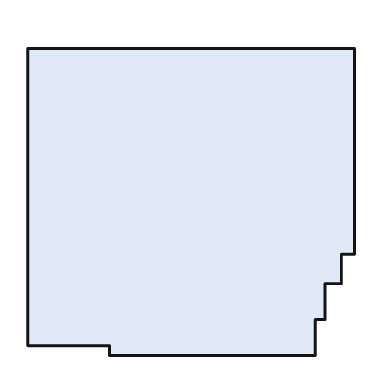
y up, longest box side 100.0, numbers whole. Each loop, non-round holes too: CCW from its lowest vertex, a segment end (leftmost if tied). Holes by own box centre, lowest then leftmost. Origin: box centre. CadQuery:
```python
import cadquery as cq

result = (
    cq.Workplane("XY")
    .moveTo(-25.0, -47.0)
    .lineTo(38.0, -47.0)
    .lineTo(38.0, -36.0)
    .lineTo(41.0, -36.0)
    .lineTo(41.0, -25.0)
    .lineTo(46.0, -25.0)
    .lineTo(46.0, -16.0)
    .lineTo(50.0, -16.0)
    .lineTo(50.0, 47.0)
    .lineTo(-50.0, 47.0)
    .lineTo(-50.0, -44.0)
    .lineTo(-25.0, -44.0)
    .close()
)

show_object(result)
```